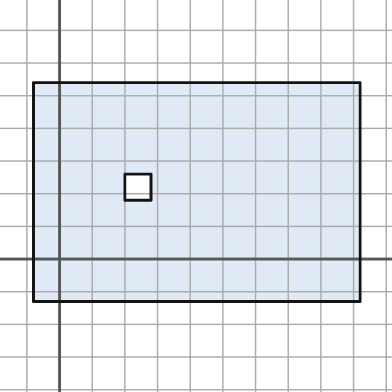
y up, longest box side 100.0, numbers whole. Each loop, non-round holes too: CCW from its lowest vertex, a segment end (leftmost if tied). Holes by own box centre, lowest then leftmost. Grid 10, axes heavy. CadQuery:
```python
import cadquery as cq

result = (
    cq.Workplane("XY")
    .moveTo(-8.0, -13.0)
    .lineTo(92.0, -13.0)
    .lineTo(92.0, 54.0)
    .lineTo(-8.0, 54.0)
    .close()
    .moveTo(20.0, 18.0)
    .lineTo(28.0, 18.0)
    .lineTo(28.0, 26.0)
    .lineTo(20.0, 26.0)
    .close()
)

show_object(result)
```